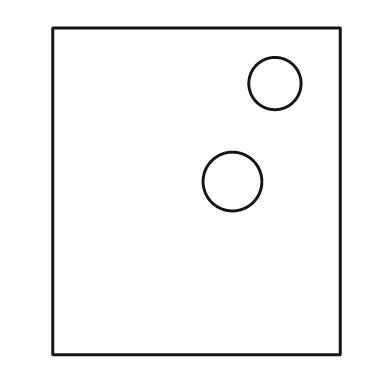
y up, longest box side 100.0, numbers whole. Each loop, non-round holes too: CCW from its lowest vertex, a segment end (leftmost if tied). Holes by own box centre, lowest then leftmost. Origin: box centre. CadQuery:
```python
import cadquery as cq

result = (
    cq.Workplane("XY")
    .moveTo(-44.0, -50.0)
    .lineTo(44.0, -50.0)
    .lineTo(44.0, 50.0)
    .lineTo(-44.0, 50.0)
    .close()
    .moveTo(11.0, 3.0)
    .circle(9.0)
    .moveTo(24.0, 33.0)
    .circle(8.0)
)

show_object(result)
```